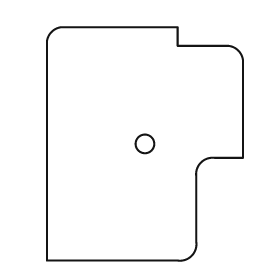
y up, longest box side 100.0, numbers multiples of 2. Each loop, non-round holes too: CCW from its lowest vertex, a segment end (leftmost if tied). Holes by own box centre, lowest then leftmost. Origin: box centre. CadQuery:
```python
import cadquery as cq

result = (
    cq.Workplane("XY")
    .moveTo(-42.0, -50.0)
    .lineTo(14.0, -50.0)
    .threePointArc((20.0, -48.0), (22.0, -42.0))
    .lineTo(22.0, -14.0)
    .threePointArc((24.0, -8.0), (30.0, -6.0))
    .lineTo(42.0, -6.0)
    .lineTo(42.0, 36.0)
    .threePointArc((40.0, 40.0), (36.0, 42.0))
    .lineTo(14.0, 42.0)
    .lineTo(14.0, 50.0)
    .lineTo(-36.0, 50.0)
    .threePointArc((-40.0, 48.0), (-42.0, 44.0))
    .close()
    .moveTo(0.0, 0.0)
    .circle(4.0)
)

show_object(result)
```